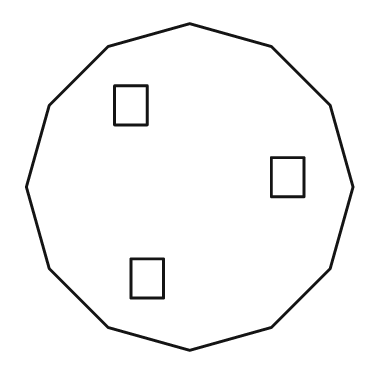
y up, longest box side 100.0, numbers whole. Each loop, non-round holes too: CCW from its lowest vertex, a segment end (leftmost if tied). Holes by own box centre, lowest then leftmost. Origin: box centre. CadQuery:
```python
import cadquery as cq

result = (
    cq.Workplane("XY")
    .moveTo(0.0, -50.0)
    .lineTo(25.0, -43.0)
    .lineTo(43.0, -25.0)
    .lineTo(50.0, 0.0)
    .lineTo(43.0, 25.0)
    .lineTo(25.0, 43.0)
    .lineTo(0.0, 50.0)
    .lineTo(-25.0, 43.0)
    .lineTo(-43.0, 25.0)
    .lineTo(-50.0, 0.0)
    .lineTo(-43.0, -25.0)
    .lineTo(-25.0, -43.0)
    .close()
    .moveTo(-18.0, -34.0)
    .lineTo(-8.0, -34.0)
    .lineTo(-8.0, -22.0)
    .lineTo(-18.0, -22.0)
    .close()
    .moveTo(25.0, -3.0)
    .lineTo(35.0, -3.0)
    .lineTo(35.0, 9.0)
    .lineTo(25.0, 9.0)
    .close()
    .moveTo(-23.0, 19.0)
    .lineTo(-13.0, 19.0)
    .lineTo(-13.0, 31.0)
    .lineTo(-23.0, 31.0)
    .close()
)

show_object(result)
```